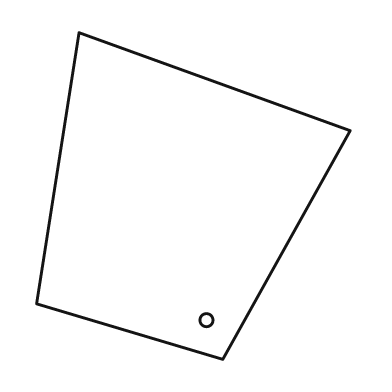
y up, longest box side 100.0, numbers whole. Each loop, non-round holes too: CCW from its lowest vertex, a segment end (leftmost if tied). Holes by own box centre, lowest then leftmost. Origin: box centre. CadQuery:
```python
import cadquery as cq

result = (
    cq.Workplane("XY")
    .moveTo(9.0, -50.0)
    .lineTo(48.0, 20.0)
    .lineTo(-35.0, 50.0)
    .lineTo(-48.0, -33.0)
    .close()
    .moveTo(4.0, -38.0)
    .circle(2.0)
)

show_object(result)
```